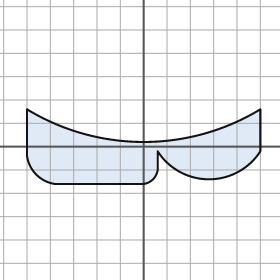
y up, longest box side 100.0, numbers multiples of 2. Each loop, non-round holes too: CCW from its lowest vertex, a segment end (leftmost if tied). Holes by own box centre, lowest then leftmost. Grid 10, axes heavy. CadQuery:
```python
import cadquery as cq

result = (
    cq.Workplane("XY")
    .moveTo(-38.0, -16.0)
    .lineTo(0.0, -16.0)
    .threePointArc((4.0, -14.0), (6.0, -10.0))
    .lineTo(6.0, -2.0)
    .threePointArc((28.0, -14.0), (50.0, -2.0))
    .lineTo(50.0, 16.0)
    .threePointArc((0.0, 2.0), (-50.0, 16.0))
    .lineTo(-50.0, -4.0)
    .threePointArc((-46.0, -12.0), (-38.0, -16.0))
    .close()
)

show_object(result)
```